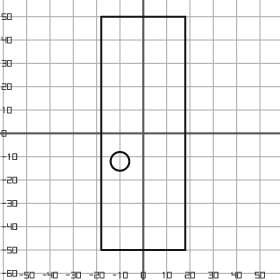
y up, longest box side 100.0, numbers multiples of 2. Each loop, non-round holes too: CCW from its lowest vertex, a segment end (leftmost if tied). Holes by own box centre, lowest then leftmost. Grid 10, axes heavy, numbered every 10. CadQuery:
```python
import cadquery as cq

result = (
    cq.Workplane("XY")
    .moveTo(-18.0, -50.0)
    .lineTo(18.0, -50.0)
    .lineTo(18.0, 50.0)
    .lineTo(-18.0, 50.0)
    .close()
    .moveTo(-10.0, -12.0)
    .circle(4.0)
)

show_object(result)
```